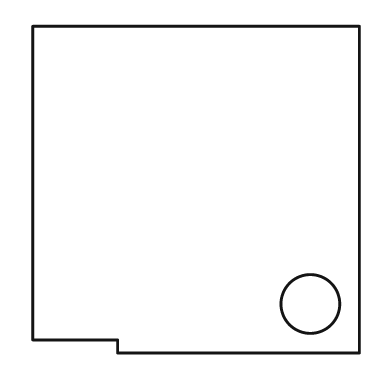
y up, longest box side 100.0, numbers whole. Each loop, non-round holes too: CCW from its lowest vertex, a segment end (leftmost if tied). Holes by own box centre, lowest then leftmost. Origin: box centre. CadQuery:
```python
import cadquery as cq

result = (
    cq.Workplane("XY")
    .moveTo(-24.0, -50.0)
    .lineTo(50.0, -50.0)
    .lineTo(50.0, 50.0)
    .lineTo(-50.0, 50.0)
    .lineTo(-50.0, -46.0)
    .lineTo(-24.0, -46.0)
    .close()
    .moveTo(35.0, -35.0)
    .circle(9.0)
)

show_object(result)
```